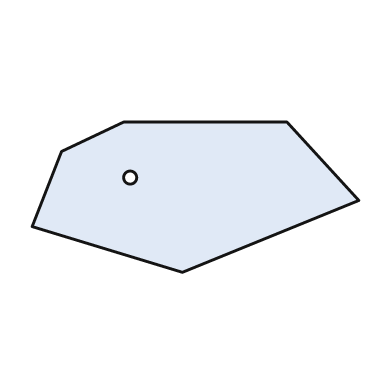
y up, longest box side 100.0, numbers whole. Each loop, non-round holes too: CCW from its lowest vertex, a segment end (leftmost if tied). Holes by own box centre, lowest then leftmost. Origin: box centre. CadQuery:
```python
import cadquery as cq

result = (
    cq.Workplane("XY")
    .moveTo(-4.0, -23.0)
    .lineTo(50.0, -1.0)
    .lineTo(28.0, 23.0)
    .lineTo(-22.0, 23.0)
    .lineTo(-41.0, 14.0)
    .lineTo(-50.0, -9.0)
    .close()
    .moveTo(-20.0, 6.0)
    .circle(2.0)
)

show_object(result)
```